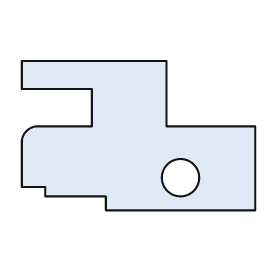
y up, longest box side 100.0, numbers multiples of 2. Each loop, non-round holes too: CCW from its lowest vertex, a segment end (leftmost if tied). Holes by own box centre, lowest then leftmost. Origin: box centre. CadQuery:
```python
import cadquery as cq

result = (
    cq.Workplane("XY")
    .moveTo(-14.0, -32.0)
    .lineTo(50.0, -32.0)
    .lineTo(50.0, 4.0)
    .lineTo(12.0, 4.0)
    .lineTo(12.0, 32.0)
    .lineTo(-50.0, 32.0)
    .lineTo(-50.0, 20.0)
    .lineTo(-20.0, 20.0)
    .lineTo(-20.0, 4.0)
    .lineTo(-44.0, 4.0)
    .threePointArc((-48.0, 2.0), (-50.0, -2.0))
    .lineTo(-50.0, -22.0)
    .lineTo(-40.0, -22.0)
    .lineTo(-40.0, -26.0)
    .lineTo(-14.0, -26.0)
    .close()
    .moveTo(18.0, -18.0)
    .circle(8.0)
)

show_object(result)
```